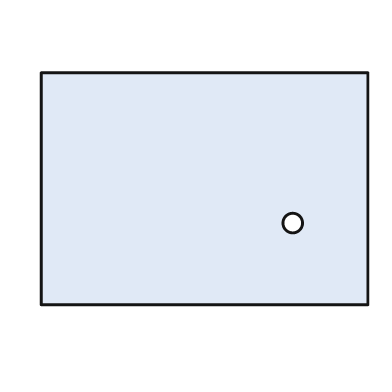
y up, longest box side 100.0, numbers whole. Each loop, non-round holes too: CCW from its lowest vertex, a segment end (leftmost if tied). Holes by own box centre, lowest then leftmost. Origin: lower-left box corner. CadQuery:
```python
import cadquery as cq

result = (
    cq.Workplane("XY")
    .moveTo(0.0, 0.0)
    .lineTo(100.0, 0.0)
    .lineTo(100.0, 71.0)
    .lineTo(0.0, 71.0)
    .close()
    .moveTo(77.0, 25.0)
    .circle(3.0)
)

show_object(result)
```